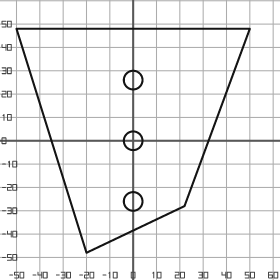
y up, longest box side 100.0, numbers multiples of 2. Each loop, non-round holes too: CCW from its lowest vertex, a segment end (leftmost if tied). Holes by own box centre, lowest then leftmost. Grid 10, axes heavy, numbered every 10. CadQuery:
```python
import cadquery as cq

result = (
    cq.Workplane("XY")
    .moveTo(-20.0, -48.0)
    .lineTo(22.0, -28.0)
    .lineTo(50.0, 48.0)
    .lineTo(-50.0, 48.0)
    .close()
    .moveTo(0.0, -26.0)
    .circle(4.0)
    .moveTo(0.0, 0.0)
    .circle(4.0)
    .moveTo(0.0, 26.0)
    .circle(4.0)
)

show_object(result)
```